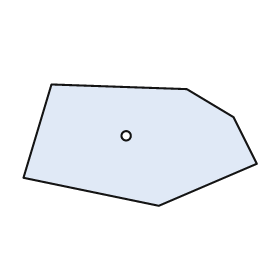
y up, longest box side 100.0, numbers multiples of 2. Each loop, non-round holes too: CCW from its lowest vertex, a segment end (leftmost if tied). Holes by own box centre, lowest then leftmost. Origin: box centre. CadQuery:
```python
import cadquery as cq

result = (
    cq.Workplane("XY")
    .moveTo(8.0, -26.0)
    .lineTo(50.0, -8.0)
    .lineTo(40.0, 12.0)
    .lineTo(20.0, 24.0)
    .lineTo(-38.0, 26.0)
    .lineTo(-50.0, -14.0)
    .close()
    .moveTo(-6.0, 4.0)
    .circle(2.0)
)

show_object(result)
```